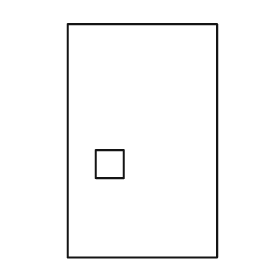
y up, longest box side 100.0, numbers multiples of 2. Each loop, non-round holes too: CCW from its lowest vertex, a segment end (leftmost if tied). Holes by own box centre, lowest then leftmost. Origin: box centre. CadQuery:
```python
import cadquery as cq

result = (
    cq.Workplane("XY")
    .moveTo(-32.0, -50.0)
    .lineTo(32.0, -50.0)
    .lineTo(32.0, 50.0)
    .lineTo(-32.0, 50.0)
    .close()
    .moveTo(-20.0, -16.0)
    .lineTo(-8.0, -16.0)
    .lineTo(-8.0, -4.0)
    .lineTo(-20.0, -4.0)
    .close()
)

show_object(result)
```